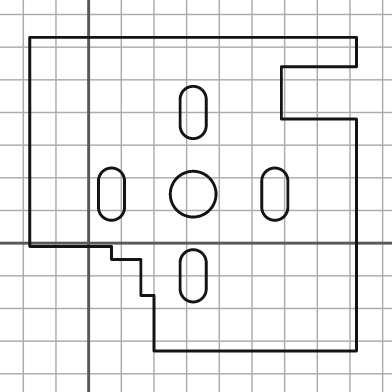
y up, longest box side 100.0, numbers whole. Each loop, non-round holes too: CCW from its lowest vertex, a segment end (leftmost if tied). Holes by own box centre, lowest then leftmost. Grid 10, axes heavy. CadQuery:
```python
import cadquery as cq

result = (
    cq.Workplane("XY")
    .moveTo(20.0, -33.0)
    .lineTo(82.0, -33.0)
    .lineTo(82.0, 38.0)
    .lineTo(59.0, 38.0)
    .lineTo(59.0, 54.0)
    .lineTo(82.0, 54.0)
    .lineTo(82.0, 63.0)
    .lineTo(-18.0, 63.0)
    .lineTo(-18.0, -1.0)
    .lineTo(7.0, -1.0)
    .lineTo(7.0, -5.0)
    .lineTo(16.0, -5.0)
    .lineTo(16.0, -16.0)
    .lineTo(20.0, -16.0)
    .close()
    .moveTo(28.0, -14.0)
    .threePointArc((32.0, -18.0), (36.0, -14.0))
    .lineTo(36.0, -6.0)
    .threePointArc((32.0, -2.0), (28.0, -6.0))
    .close()
    .moveTo(3.0, 11.0)
    .threePointArc((7.0, 7.0), (11.0, 11.0))
    .lineTo(11.0, 19.0)
    .threePointArc((7.0, 23.0), (3.0, 19.0))
    .close()
    .moveTo(32.0, 15.0)
    .circle(7.0)
    .moveTo(53.0, 11.0)
    .threePointArc((57.0, 7.0), (61.0, 11.0))
    .lineTo(61.0, 19.0)
    .threePointArc((57.0, 23.0), (53.0, 19.0))
    .close()
    .moveTo(28.0, 36.0)
    .threePointArc((32.0, 32.0), (36.0, 36.0))
    .lineTo(36.0, 44.0)
    .threePointArc((32.0, 48.0), (28.0, 44.0))
    .close()
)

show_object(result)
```